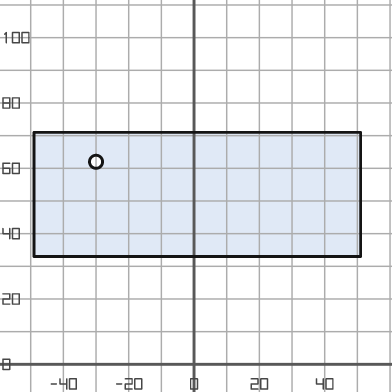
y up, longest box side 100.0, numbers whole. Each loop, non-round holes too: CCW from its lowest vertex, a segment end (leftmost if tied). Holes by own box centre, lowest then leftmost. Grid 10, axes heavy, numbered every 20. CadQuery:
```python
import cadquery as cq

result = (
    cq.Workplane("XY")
    .moveTo(-49.0, 33.0)
    .lineTo(51.0, 33.0)
    .lineTo(51.0, 71.0)
    .lineTo(-49.0, 71.0)
    .close()
    .moveTo(-30.0, 62.0)
    .circle(2.0)
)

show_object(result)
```